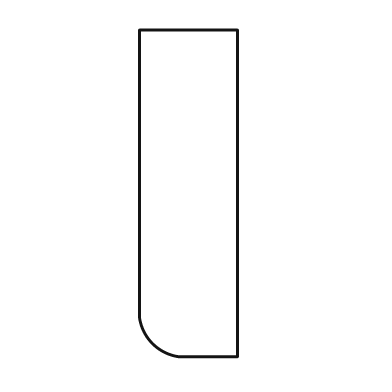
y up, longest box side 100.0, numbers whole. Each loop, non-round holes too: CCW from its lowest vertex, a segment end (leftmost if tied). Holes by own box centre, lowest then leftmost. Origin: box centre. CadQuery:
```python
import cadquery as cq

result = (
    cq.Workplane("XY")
    .moveTo(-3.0, -50.0)
    .lineTo(15.0, -50.0)
    .lineTo(15.0, 50.0)
    .lineTo(-15.0, 50.0)
    .lineTo(-15.0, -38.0)
    .threePointArc((-11.0, -46.0), (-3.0, -50.0))
    .close()
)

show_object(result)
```